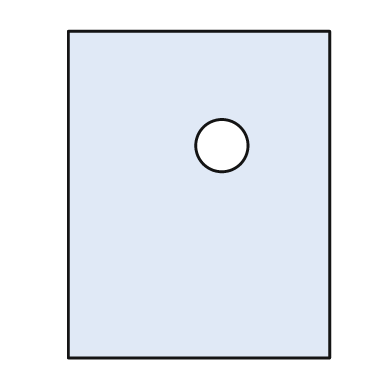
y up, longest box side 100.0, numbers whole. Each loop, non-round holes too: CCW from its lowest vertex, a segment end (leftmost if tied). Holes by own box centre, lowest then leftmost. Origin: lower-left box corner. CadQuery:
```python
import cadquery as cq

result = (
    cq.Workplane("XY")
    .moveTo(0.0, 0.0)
    .lineTo(80.0, 0.0)
    .lineTo(80.0, 100.0)
    .lineTo(0.0, 100.0)
    .close()
    .moveTo(47.0, 65.0)
    .circle(8.0)
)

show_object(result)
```